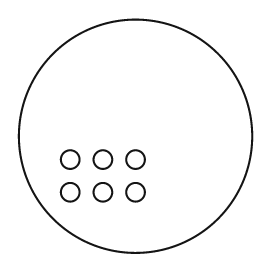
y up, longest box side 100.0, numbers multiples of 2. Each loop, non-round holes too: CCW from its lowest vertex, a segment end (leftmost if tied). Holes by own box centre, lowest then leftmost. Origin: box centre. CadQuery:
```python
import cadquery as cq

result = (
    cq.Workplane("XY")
    .moveTo(0.0, 0.0)
    .circle(50.0)
    .moveTo(-28.0, -24.0)
    .circle(4.0)
    .moveTo(-14.0, -24.0)
    .circle(4.0)
    .moveTo(0.0, -24.0)
    .circle(4.0)
    .moveTo(-28.0, -10.0)
    .circle(4.0)
    .moveTo(-14.0, -10.0)
    .circle(4.0)
    .moveTo(0.0, -10.0)
    .circle(4.0)
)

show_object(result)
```